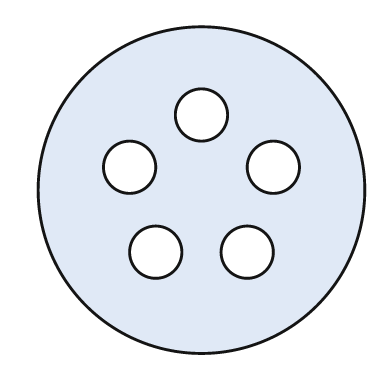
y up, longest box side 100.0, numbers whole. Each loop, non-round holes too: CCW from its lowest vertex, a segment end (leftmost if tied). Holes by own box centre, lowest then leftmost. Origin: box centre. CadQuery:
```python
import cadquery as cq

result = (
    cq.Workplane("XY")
    .moveTo(0.0, 0.0)
    .circle(50.0)
    .moveTo(-14.0, -19.0)
    .circle(8.0)
    .moveTo(14.0, -19.0)
    .circle(8.0)
    .moveTo(-22.0, 7.0)
    .circle(8.0)
    .moveTo(22.0, 7.0)
    .circle(8.0)
    .moveTo(0.0, 23.0)
    .circle(8.0)
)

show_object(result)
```